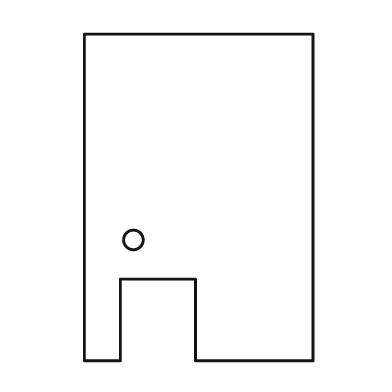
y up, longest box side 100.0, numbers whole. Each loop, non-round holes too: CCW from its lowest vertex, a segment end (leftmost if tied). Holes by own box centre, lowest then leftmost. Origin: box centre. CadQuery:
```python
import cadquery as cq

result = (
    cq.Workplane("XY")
    .moveTo(-35.0, -50.0)
    .lineTo(-24.0, -50.0)
    .lineTo(-24.0, -25.0)
    .lineTo(-1.0, -25.0)
    .lineTo(-1.0, -50.0)
    .lineTo(35.0, -50.0)
    .lineTo(35.0, 50.0)
    .lineTo(-35.0, 50.0)
    .close()
    .moveTo(-20.0, -13.0)
    .circle(3.0)
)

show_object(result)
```